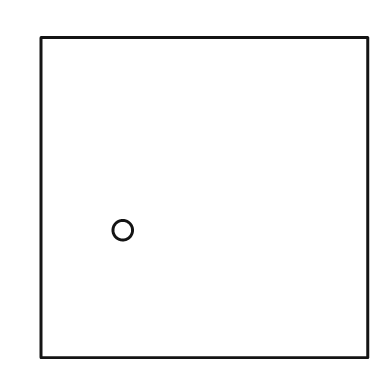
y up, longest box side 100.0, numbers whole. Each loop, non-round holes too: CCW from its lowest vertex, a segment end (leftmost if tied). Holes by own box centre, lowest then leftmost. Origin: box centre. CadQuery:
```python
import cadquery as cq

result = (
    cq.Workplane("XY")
    .moveTo(-50.0, -49.0)
    .lineTo(50.0, -49.0)
    .lineTo(50.0, 49.0)
    .lineTo(-50.0, 49.0)
    .close()
    .moveTo(-25.0, -10.0)
    .circle(3.0)
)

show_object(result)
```